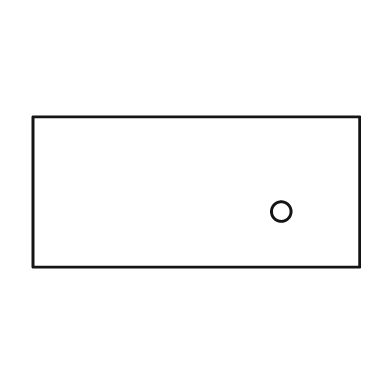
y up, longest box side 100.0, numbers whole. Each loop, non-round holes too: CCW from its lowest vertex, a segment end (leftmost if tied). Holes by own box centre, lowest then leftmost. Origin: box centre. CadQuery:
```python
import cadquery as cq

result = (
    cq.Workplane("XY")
    .moveTo(-50.0, -23.0)
    .lineTo(50.0, -23.0)
    .lineTo(50.0, 23.0)
    .lineTo(-50.0, 23.0)
    .close()
    .moveTo(26.0, -6.0)
    .circle(3.0)
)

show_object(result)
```